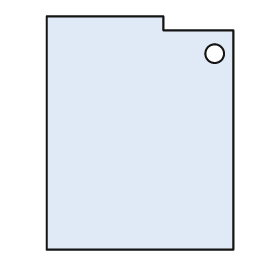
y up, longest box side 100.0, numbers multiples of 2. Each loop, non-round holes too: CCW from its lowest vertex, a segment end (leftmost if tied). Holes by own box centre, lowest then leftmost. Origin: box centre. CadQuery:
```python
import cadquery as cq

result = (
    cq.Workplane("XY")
    .moveTo(-40.0, -50.0)
    .lineTo(40.0, -50.0)
    .lineTo(40.0, 44.0)
    .lineTo(10.0, 44.0)
    .lineTo(10.0, 50.0)
    .lineTo(-40.0, 50.0)
    .close()
    .moveTo(32.0, 34.0)
    .circle(4.0)
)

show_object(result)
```